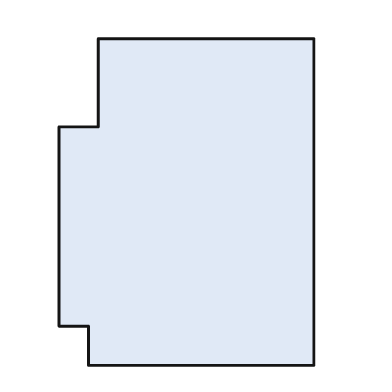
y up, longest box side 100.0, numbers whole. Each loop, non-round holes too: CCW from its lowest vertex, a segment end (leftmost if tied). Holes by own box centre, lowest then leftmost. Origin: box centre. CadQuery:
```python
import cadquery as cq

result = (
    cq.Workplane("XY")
    .moveTo(-30.0, -50.0)
    .lineTo(39.0, -50.0)
    .lineTo(39.0, 50.0)
    .lineTo(-27.0, 50.0)
    .lineTo(-27.0, 23.0)
    .lineTo(-39.0, 23.0)
    .lineTo(-39.0, -38.0)
    .lineTo(-30.0, -38.0)
    .close()
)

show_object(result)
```